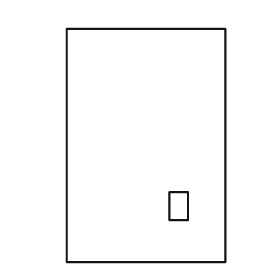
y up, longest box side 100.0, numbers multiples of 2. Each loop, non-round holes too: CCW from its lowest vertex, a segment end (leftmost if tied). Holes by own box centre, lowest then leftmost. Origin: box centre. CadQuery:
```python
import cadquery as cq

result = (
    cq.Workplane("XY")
    .moveTo(-34.0, -50.0)
    .lineTo(34.0, -50.0)
    .lineTo(34.0, 50.0)
    .lineTo(-34.0, 50.0)
    .close()
    .moveTo(10.0, -32.0)
    .lineTo(18.0, -32.0)
    .lineTo(18.0, -20.0)
    .lineTo(10.0, -20.0)
    .close()
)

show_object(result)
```